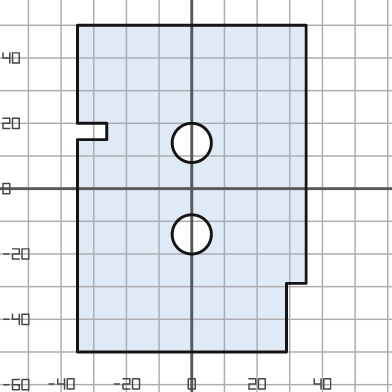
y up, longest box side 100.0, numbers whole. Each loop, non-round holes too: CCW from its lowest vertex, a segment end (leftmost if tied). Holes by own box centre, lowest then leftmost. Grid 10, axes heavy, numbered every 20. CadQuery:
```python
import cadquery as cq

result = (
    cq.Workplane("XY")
    .moveTo(-35.0, -50.0)
    .lineTo(29.0, -50.0)
    .lineTo(29.0, -29.0)
    .lineTo(35.0, -29.0)
    .lineTo(35.0, 50.0)
    .lineTo(-35.0, 50.0)
    .lineTo(-35.0, 20.0)
    .lineTo(-26.0, 20.0)
    .lineTo(-26.0, 15.0)
    .lineTo(-35.0, 15.0)
    .close()
    .moveTo(0.0, -14.0)
    .circle(6.0)
    .moveTo(0.0, 14.0)
    .circle(6.0)
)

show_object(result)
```